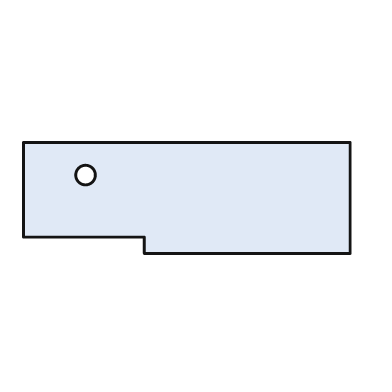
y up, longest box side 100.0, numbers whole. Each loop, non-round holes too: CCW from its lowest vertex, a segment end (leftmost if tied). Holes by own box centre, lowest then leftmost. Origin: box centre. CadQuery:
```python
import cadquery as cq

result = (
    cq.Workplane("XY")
    .moveTo(-13.0, -17.0)
    .lineTo(50.0, -17.0)
    .lineTo(50.0, 17.0)
    .lineTo(-50.0, 17.0)
    .lineTo(-50.0, -12.0)
    .lineTo(-13.0, -12.0)
    .close()
    .moveTo(-31.0, 7.0)
    .circle(3.0)
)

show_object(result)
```